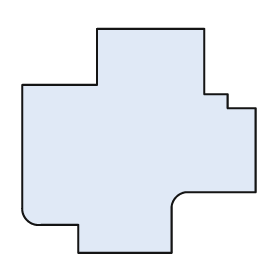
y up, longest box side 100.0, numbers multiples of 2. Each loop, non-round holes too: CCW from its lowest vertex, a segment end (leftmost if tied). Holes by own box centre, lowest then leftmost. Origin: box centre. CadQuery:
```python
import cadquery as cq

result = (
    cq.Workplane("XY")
    .moveTo(-26.0, -48.0)
    .lineTo(14.0, -48.0)
    .lineTo(14.0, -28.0)
    .threePointArc((16.0, -24.0), (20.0, -22.0))
    .lineTo(50.0, -22.0)
    .lineTo(50.0, 14.0)
    .lineTo(38.0, 14.0)
    .lineTo(38.0, 20.0)
    .lineTo(28.0, 20.0)
    .lineTo(28.0, 48.0)
    .lineTo(-18.0, 48.0)
    .lineTo(-18.0, 24.0)
    .lineTo(-50.0, 24.0)
    .lineTo(-50.0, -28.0)
    .threePointArc((-48.0, -34.0), (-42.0, -36.0))
    .lineTo(-26.0, -36.0)
    .close()
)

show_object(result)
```